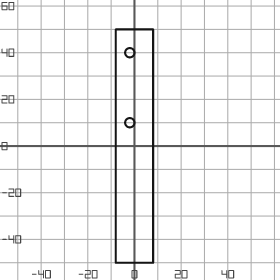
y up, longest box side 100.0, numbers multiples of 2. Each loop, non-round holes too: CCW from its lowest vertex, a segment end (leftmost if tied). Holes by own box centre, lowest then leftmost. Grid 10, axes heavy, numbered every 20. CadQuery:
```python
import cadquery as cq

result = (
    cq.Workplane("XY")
    .moveTo(-8.0, -50.0)
    .lineTo(8.0, -50.0)
    .lineTo(8.0, 50.0)
    .lineTo(-8.0, 50.0)
    .close()
    .moveTo(-2.0, 10.0)
    .circle(2.0)
    .moveTo(-2.0, 40.0)
    .circle(2.0)
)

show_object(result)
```